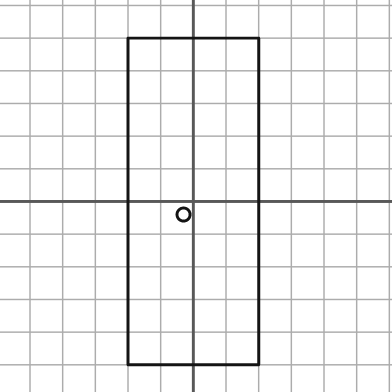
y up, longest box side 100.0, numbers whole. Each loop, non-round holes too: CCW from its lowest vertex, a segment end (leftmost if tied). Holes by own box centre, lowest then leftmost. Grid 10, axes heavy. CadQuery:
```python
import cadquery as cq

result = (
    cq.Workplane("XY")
    .moveTo(-20.0, -50.0)
    .lineTo(20.0, -50.0)
    .lineTo(20.0, 50.0)
    .lineTo(-20.0, 50.0)
    .close()
    .moveTo(-3.0, -4.0)
    .circle(2.0)
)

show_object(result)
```